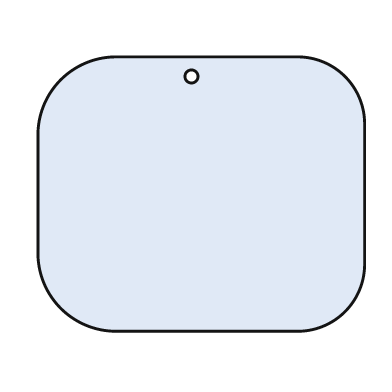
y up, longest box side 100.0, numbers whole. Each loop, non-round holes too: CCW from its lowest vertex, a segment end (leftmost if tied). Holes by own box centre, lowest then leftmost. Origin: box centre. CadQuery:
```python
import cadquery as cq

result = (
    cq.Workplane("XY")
    .moveTo(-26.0, -42.0)
    .lineTo(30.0, -42.0)
    .threePointArc((44.0, -36.0), (50.0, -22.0))
    .lineTo(50.0, 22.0)
    .threePointArc((44.0, 36.0), (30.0, 42.0))
    .lineTo(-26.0, 42.0)
    .threePointArc((-43.0, 35.0), (-50.0, 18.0))
    .lineTo(-50.0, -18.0)
    .threePointArc((-43.0, -35.0), (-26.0, -42.0))
    .close()
    .moveTo(-3.0, 36.0)
    .circle(2.0)
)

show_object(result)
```